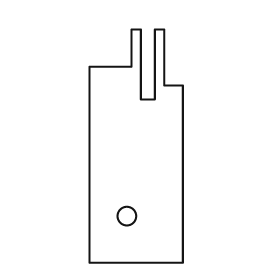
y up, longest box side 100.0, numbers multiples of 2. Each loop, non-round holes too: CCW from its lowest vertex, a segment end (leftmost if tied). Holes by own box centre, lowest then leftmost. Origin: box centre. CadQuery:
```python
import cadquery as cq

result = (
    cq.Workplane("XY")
    .moveTo(-20.0, -50.0)
    .lineTo(20.0, -50.0)
    .lineTo(20.0, 26.0)
    .lineTo(12.0, 26.0)
    .lineTo(12.0, 50.0)
    .lineTo(8.0, 50.0)
    .lineTo(8.0, 20.0)
    .lineTo(2.0, 20.0)
    .lineTo(2.0, 50.0)
    .lineTo(-2.0, 50.0)
    .lineTo(-2.0, 34.0)
    .lineTo(-20.0, 34.0)
    .close()
    .moveTo(-4.0, -30.0)
    .circle(4.0)
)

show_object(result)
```